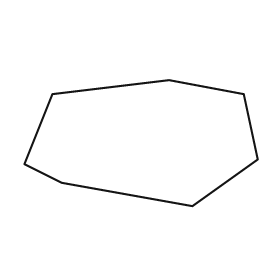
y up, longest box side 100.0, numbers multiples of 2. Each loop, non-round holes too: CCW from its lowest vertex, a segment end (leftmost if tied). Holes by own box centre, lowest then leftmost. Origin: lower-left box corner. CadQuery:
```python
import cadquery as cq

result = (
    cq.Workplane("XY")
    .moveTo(72.0, 0.0)
    .lineTo(100.0, 20.0)
    .lineTo(94.0, 48.0)
    .lineTo(62.0, 54.0)
    .lineTo(12.0, 48.0)
    .lineTo(0.0, 18.0)
    .lineTo(16.0, 10.0)
    .close()
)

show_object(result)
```